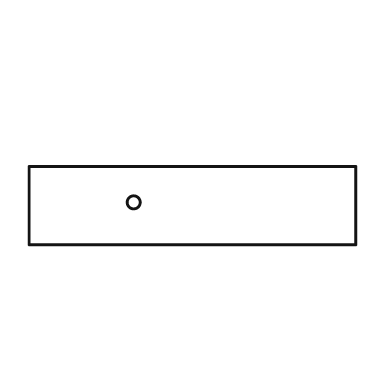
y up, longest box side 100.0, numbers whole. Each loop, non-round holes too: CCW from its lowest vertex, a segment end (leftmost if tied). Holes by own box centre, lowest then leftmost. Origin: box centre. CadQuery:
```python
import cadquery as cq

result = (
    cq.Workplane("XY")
    .moveTo(-50.0, -12.0)
    .lineTo(50.0, -12.0)
    .lineTo(50.0, 12.0)
    .lineTo(-50.0, 12.0)
    .close()
    .moveTo(-18.0, 1.0)
    .circle(2.0)
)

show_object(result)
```